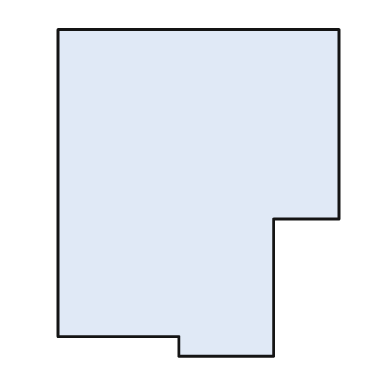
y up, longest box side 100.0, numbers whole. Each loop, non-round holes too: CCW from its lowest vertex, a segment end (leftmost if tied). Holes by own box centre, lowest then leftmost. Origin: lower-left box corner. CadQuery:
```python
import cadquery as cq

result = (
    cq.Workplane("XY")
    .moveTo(37.0, 0.0)
    .lineTo(66.0, 0.0)
    .lineTo(66.0, 42.0)
    .lineTo(86.0, 42.0)
    .lineTo(86.0, 100.0)
    .lineTo(0.0, 100.0)
    .lineTo(0.0, 6.0)
    .lineTo(37.0, 6.0)
    .close()
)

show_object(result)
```